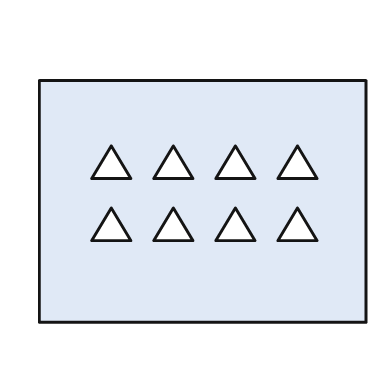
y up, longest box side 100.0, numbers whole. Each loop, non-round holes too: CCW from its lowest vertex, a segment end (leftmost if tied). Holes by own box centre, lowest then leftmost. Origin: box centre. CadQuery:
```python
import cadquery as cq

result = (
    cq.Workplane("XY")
    .moveTo(-50.0, -37.0)
    .lineTo(50.0, -37.0)
    .lineTo(50.0, 37.0)
    .lineTo(-50.0, 37.0)
    .close()
    .moveTo(-34.0, -12.0)
    .lineTo(-22.0, -12.0)
    .lineTo(-28.0, -2.0)
    .close()
    .moveTo(-15.0, -12.0)
    .lineTo(-3.0, -12.0)
    .lineTo(-9.0, -2.0)
    .close()
    .moveTo(4.0, -12.0)
    .lineTo(16.0, -12.0)
    .lineTo(10.0, -2.0)
    .close()
    .moveTo(23.0, -12.0)
    .lineTo(35.0, -12.0)
    .lineTo(29.0, -2.0)
    .close()
    .moveTo(-34.0, 7.0)
    .lineTo(-22.0, 7.0)
    .lineTo(-28.0, 17.0)
    .close()
    .moveTo(-15.0, 7.0)
    .lineTo(-3.0, 7.0)
    .lineTo(-9.0, 17.0)
    .close()
    .moveTo(4.0, 7.0)
    .lineTo(16.0, 7.0)
    .lineTo(10.0, 17.0)
    .close()
    .moveTo(23.0, 7.0)
    .lineTo(35.0, 7.0)
    .lineTo(29.0, 17.0)
    .close()
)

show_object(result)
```